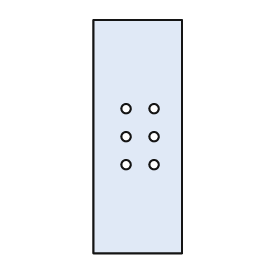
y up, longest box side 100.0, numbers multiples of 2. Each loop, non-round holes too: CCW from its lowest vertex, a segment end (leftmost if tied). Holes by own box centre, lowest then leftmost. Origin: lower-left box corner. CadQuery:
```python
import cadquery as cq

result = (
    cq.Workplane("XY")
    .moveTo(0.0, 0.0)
    .lineTo(38.0, 0.0)
    .lineTo(38.0, 100.0)
    .lineTo(0.0, 100.0)
    .close()
    .moveTo(14.0, 38.0)
    .circle(2.0)
    .moveTo(26.0, 38.0)
    .circle(2.0)
    .moveTo(14.0, 50.0)
    .circle(2.0)
    .moveTo(26.0, 50.0)
    .circle(2.0)
    .moveTo(14.0, 62.0)
    .circle(2.0)
    .moveTo(26.0, 62.0)
    .circle(2.0)
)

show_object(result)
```